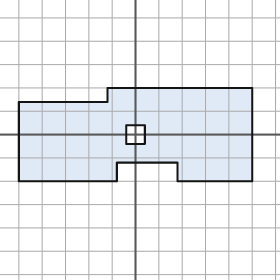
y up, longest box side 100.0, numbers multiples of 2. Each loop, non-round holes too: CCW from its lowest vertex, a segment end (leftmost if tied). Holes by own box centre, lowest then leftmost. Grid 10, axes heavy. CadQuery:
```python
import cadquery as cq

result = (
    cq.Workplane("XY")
    .moveTo(-50.0, -20.0)
    .lineTo(-8.0, -20.0)
    .lineTo(-8.0, -12.0)
    .lineTo(18.0, -12.0)
    .lineTo(18.0, -20.0)
    .lineTo(50.0, -20.0)
    .lineTo(50.0, 20.0)
    .lineTo(-12.0, 20.0)
    .lineTo(-12.0, 14.0)
    .lineTo(-50.0, 14.0)
    .close()
    .moveTo(-4.0, -4.0)
    .lineTo(4.0, -4.0)
    .lineTo(4.0, 4.0)
    .lineTo(-4.0, 4.0)
    .close()
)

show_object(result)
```